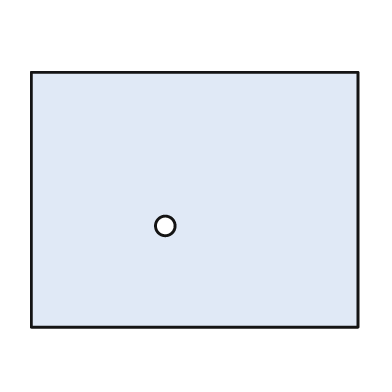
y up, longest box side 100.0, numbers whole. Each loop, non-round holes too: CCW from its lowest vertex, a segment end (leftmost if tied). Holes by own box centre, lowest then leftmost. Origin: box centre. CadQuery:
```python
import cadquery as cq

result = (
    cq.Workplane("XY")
    .moveTo(-50.0, -39.0)
    .lineTo(50.0, -39.0)
    .lineTo(50.0, 39.0)
    .lineTo(-50.0, 39.0)
    .close()
    .moveTo(-9.0, -8.0)
    .circle(3.0)
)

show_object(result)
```